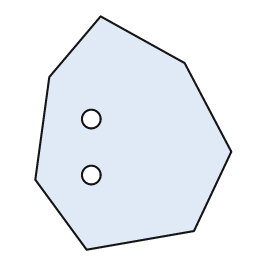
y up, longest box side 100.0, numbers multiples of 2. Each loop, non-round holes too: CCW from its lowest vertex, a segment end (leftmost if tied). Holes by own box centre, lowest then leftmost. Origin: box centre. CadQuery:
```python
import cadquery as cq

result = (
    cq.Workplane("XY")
    .moveTo(-20.0, -50.0)
    .lineTo(26.0, -42.0)
    .lineTo(42.0, -8.0)
    .lineTo(22.0, 30.0)
    .lineTo(-14.0, 50.0)
    .lineTo(-36.0, 24.0)
    .lineTo(-42.0, -20.0)
    .close()
    .moveTo(-18.0, -18.0)
    .circle(4.0)
    .moveTo(-18.0, 6.0)
    .circle(4.0)
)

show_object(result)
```